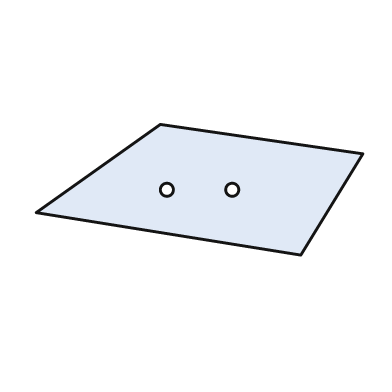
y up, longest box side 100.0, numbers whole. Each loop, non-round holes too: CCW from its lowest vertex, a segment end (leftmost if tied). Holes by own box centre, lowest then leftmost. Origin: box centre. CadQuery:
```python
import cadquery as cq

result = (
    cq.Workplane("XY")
    .moveTo(31.0, -20.0)
    .lineTo(50.0, 11.0)
    .lineTo(-12.0, 20.0)
    .lineTo(-50.0, -7.0)
    .close()
    .moveTo(-10.0, 0.0)
    .circle(2.0)
    .moveTo(10.0, 0.0)
    .circle(2.0)
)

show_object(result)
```